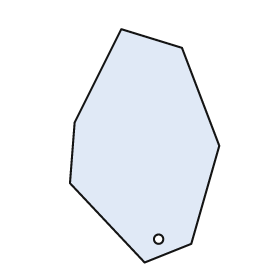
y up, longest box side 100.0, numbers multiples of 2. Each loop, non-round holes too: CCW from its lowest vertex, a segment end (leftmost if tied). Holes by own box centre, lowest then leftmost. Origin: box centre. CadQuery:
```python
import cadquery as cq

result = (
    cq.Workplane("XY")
    .moveTo(0.0, -50.0)
    .lineTo(20.0, -42.0)
    .lineTo(32.0, 0.0)
    .lineTo(16.0, 42.0)
    .lineTo(-10.0, 50.0)
    .lineTo(-30.0, 10.0)
    .lineTo(-32.0, -16.0)
    .close()
    .moveTo(6.0, -40.0)
    .circle(2.0)
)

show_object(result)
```